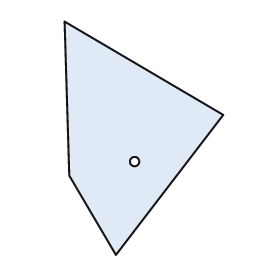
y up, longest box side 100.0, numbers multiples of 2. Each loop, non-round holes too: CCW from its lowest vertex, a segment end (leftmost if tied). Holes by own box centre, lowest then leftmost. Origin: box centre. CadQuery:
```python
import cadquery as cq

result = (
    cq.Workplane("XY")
    .moveTo(-12.0, -50.0)
    .lineTo(34.0, 10.0)
    .lineTo(-34.0, 50.0)
    .lineTo(-32.0, -16.0)
    .close()
    .moveTo(-4.0, -10.0)
    .circle(2.0)
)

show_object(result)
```